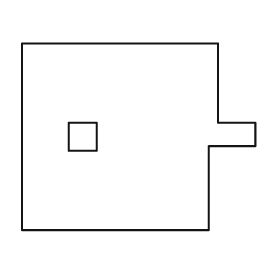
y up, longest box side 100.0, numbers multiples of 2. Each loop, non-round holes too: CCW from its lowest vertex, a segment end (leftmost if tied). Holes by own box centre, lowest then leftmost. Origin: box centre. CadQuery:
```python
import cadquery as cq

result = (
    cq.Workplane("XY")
    .moveTo(-50.0, -40.0)
    .lineTo(30.0, -40.0)
    .lineTo(30.0, -4.0)
    .lineTo(50.0, -4.0)
    .lineTo(50.0, 6.0)
    .lineTo(34.0, 6.0)
    .lineTo(34.0, 40.0)
    .lineTo(-50.0, 40.0)
    .close()
    .moveTo(-30.0, -6.0)
    .lineTo(-18.0, -6.0)
    .lineTo(-18.0, 6.0)
    .lineTo(-30.0, 6.0)
    .close()
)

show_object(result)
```